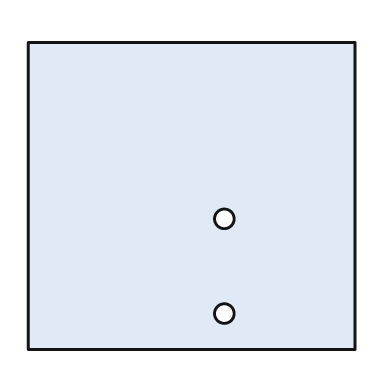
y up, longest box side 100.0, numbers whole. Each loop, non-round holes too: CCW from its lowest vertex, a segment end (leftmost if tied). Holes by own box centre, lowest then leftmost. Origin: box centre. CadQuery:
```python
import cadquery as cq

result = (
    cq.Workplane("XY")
    .moveTo(-50.0, -47.0)
    .lineTo(50.0, -47.0)
    .lineTo(50.0, 47.0)
    .lineTo(-50.0, 47.0)
    .close()
    .moveTo(10.0, -36.0)
    .circle(3.0)
    .moveTo(10.0, -7.0)
    .circle(3.0)
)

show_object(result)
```